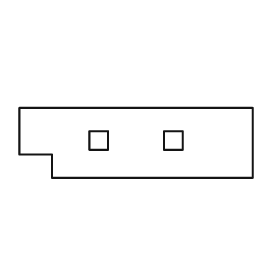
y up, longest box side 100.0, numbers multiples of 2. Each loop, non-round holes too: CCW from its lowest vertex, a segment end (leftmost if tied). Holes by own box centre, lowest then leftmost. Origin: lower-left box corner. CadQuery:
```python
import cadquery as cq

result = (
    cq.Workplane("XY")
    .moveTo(14.0, 0.0)
    .lineTo(100.0, 0.0)
    .lineTo(100.0, 30.0)
    .lineTo(0.0, 30.0)
    .lineTo(0.0, 10.0)
    .lineTo(14.0, 10.0)
    .close()
    .moveTo(30.0, 12.0)
    .lineTo(38.0, 12.0)
    .lineTo(38.0, 20.0)
    .lineTo(30.0, 20.0)
    .close()
    .moveTo(62.0, 12.0)
    .lineTo(70.0, 12.0)
    .lineTo(70.0, 20.0)
    .lineTo(62.0, 20.0)
    .close()
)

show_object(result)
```